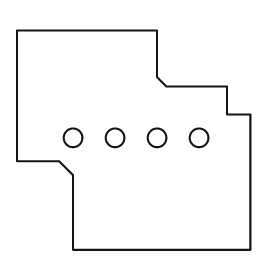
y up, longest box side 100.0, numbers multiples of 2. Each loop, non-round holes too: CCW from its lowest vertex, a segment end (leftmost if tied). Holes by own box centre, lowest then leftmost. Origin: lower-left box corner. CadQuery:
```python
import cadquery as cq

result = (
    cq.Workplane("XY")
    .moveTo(24.0, 0.0)
    .lineTo(100.0, 0.0)
    .lineTo(100.0, 58.0)
    .lineTo(90.0, 58.0)
    .lineTo(90.0, 70.0)
    .lineTo(64.0, 70.0)
    .lineTo(60.0, 74.0)
    .lineTo(60.0, 94.0)
    .lineTo(0.0, 94.0)
    .lineTo(0.0, 38.0)
    .lineTo(18.0, 38.0)
    .lineTo(24.0, 32.0)
    .close()
    .moveTo(24.0, 48.0)
    .circle(4.0)
    .moveTo(42.0, 48.0)
    .circle(4.0)
    .moveTo(60.0, 48.0)
    .circle(4.0)
    .moveTo(78.0, 48.0)
    .circle(4.0)
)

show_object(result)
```